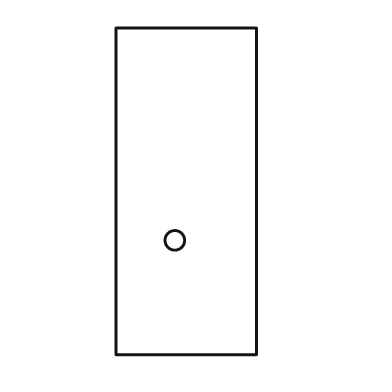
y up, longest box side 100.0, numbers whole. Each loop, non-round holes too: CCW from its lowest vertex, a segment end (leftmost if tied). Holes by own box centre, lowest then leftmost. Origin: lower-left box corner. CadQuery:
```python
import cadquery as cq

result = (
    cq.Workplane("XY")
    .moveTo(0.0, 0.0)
    .lineTo(43.0, 0.0)
    .lineTo(43.0, 100.0)
    .lineTo(0.0, 100.0)
    .close()
    .moveTo(18.0, 35.0)
    .circle(3.0)
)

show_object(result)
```